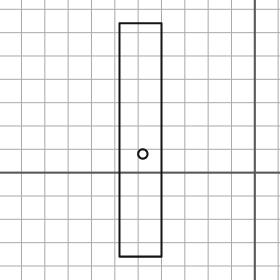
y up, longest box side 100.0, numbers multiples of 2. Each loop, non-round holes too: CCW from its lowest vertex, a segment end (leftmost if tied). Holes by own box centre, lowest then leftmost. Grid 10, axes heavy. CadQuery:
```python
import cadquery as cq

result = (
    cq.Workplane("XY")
    .moveTo(-58.0, -36.0)
    .lineTo(-40.0, -36.0)
    .lineTo(-40.0, 64.0)
    .lineTo(-58.0, 64.0)
    .close()
    .moveTo(-48.0, 8.0)
    .circle(2.0)
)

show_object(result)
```